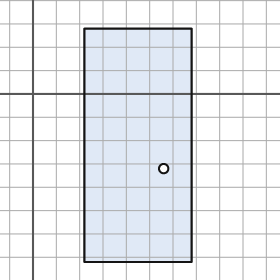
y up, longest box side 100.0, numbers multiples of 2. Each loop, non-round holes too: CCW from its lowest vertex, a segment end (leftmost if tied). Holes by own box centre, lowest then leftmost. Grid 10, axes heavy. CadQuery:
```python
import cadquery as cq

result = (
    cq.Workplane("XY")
    .moveTo(22.0, -72.0)
    .lineTo(68.0, -72.0)
    .lineTo(68.0, 28.0)
    .lineTo(22.0, 28.0)
    .close()
    .moveTo(56.0, -32.0)
    .circle(2.0)
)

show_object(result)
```